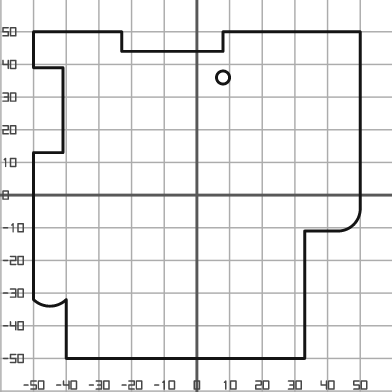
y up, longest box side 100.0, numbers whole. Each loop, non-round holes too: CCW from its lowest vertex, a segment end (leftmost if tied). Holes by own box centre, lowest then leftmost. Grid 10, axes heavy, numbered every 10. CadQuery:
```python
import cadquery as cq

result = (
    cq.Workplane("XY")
    .moveTo(-40.0, -50.0)
    .lineTo(33.0, -50.0)
    .lineTo(33.0, -11.0)
    .lineTo(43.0, -11.0)
    .threePointArc((48.0, -9.0), (50.0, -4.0))
    .lineTo(50.0, 50.0)
    .lineTo(8.0, 50.0)
    .lineTo(8.0, 44.0)
    .lineTo(-23.0, 44.0)
    .lineTo(-23.0, 50.0)
    .lineTo(-50.0, 50.0)
    .lineTo(-50.0, 39.0)
    .lineTo(-41.0, 39.0)
    .lineTo(-41.0, 13.0)
    .lineTo(-50.0, 13.0)
    .lineTo(-50.0, -32.0)
    .threePointArc((-45.0, -34.0), (-40.0, -32.0))
    .close()
    .moveTo(8.0, 36.0)
    .circle(2.0)
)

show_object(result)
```